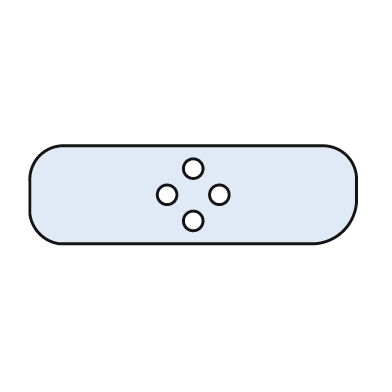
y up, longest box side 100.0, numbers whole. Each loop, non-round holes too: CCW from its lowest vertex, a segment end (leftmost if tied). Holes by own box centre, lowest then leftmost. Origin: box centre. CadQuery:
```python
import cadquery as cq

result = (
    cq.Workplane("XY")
    .moveTo(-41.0, -15.0)
    .lineTo(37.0, -15.0)
    .threePointArc((46.0, -11.0), (50.0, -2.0))
    .lineTo(50.0, 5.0)
    .threePointArc((47.0, 12.0), (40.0, 15.0))
    .lineTo(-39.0, 15.0)
    .threePointArc((-47.0, 12.0), (-50.0, 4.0))
    .lineTo(-50.0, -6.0)
    .threePointArc((-47.0, -12.0), (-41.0, -15.0))
    .close()
    .moveTo(0.0, -8.0)
    .circle(3.0)
    .moveTo(-8.0, 0.0)
    .circle(3.0)
    .moveTo(8.0, 0.0)
    .circle(3.0)
    .moveTo(0.0, 8.0)
    .circle(3.0)
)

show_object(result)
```